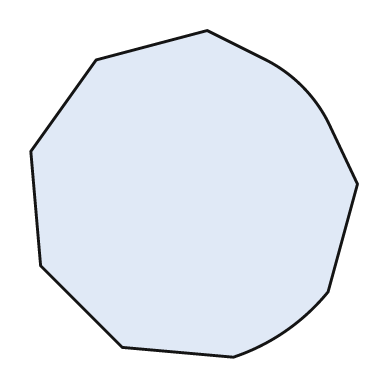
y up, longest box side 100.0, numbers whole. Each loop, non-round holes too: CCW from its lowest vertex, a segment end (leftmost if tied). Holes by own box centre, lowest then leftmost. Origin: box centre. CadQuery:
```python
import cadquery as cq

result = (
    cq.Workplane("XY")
    .moveTo(12.0, -50.0)
    .threePointArc((28.0, -42.0), (41.0, -30.0))
    .lineTo(50.0, 3.0)
    .lineTo(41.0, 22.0)
    .threePointArc((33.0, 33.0), (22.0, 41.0))
    .lineTo(4.0, 50.0)
    .lineTo(-30.0, 41.0)
    .lineTo(-50.0, 13.0)
    .lineTo(-47.0, -22.0)
    .lineTo(-22.0, -47.0)
    .close()
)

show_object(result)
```